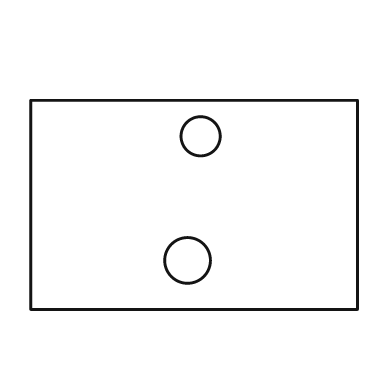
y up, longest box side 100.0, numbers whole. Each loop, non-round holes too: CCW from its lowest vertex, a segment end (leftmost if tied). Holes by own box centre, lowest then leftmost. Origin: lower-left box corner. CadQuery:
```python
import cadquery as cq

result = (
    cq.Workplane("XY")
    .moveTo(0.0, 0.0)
    .lineTo(100.0, 0.0)
    .lineTo(100.0, 64.0)
    .lineTo(0.0, 64.0)
    .close()
    .moveTo(48.0, 15.0)
    .circle(7.0)
    .moveTo(52.0, 53.0)
    .circle(6.0)
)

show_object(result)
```